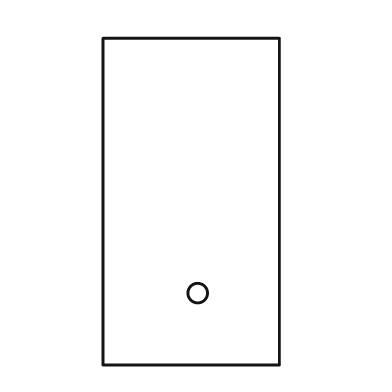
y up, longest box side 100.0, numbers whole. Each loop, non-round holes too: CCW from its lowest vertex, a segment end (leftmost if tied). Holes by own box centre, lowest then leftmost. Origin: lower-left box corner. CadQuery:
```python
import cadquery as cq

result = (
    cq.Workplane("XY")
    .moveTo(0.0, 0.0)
    .lineTo(54.0, 0.0)
    .lineTo(54.0, 100.0)
    .lineTo(0.0, 100.0)
    .close()
    .moveTo(29.0, 22.0)
    .circle(3.0)
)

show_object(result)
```